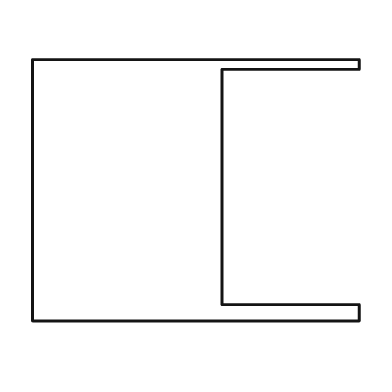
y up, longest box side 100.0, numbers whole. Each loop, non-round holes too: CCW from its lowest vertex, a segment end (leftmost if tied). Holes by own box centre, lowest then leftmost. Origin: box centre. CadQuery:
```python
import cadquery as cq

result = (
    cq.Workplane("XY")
    .moveTo(-50.0, -40.0)
    .lineTo(50.0, -40.0)
    .lineTo(50.0, -35.0)
    .lineTo(8.0, -35.0)
    .lineTo(8.0, 37.0)
    .lineTo(50.0, 37.0)
    .lineTo(50.0, 40.0)
    .lineTo(-50.0, 40.0)
    .close()
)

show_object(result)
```